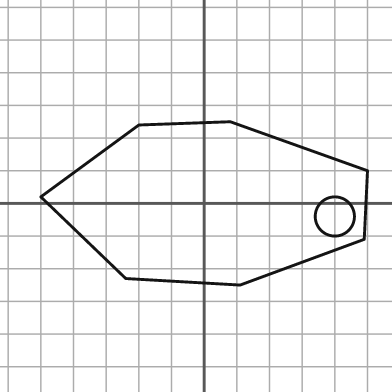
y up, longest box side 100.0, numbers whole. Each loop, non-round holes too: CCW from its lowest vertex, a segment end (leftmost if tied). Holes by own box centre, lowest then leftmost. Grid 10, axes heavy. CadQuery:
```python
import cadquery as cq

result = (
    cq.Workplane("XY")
    .moveTo(11.0, -25.0)
    .lineTo(49.0, -11.0)
    .lineTo(50.0, 10.0)
    .lineTo(8.0, 25.0)
    .lineTo(-20.0, 24.0)
    .lineTo(-50.0, 2.0)
    .lineTo(-24.0, -23.0)
    .close()
    .moveTo(40.0, -4.0)
    .circle(6.0)
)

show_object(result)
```